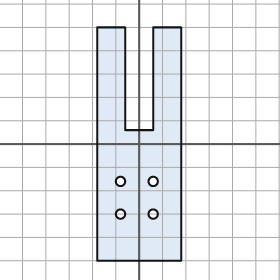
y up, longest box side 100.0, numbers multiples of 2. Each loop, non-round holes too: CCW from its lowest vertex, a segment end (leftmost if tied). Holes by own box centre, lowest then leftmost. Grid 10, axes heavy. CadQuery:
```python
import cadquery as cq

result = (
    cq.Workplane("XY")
    .moveTo(-18.0, -50.0)
    .lineTo(18.0, -50.0)
    .lineTo(18.0, 50.0)
    .lineTo(6.0, 50.0)
    .lineTo(6.0, 6.0)
    .lineTo(-6.0, 6.0)
    .lineTo(-6.0, 50.0)
    .lineTo(-18.0, 50.0)
    .close()
    .moveTo(-8.0, -30.0)
    .circle(2.0)
    .moveTo(6.0, -30.0)
    .circle(2.0)
    .moveTo(-8.0, -16.0)
    .circle(2.0)
    .moveTo(6.0, -16.0)
    .circle(2.0)
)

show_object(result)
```